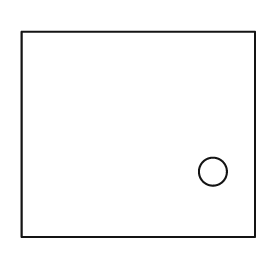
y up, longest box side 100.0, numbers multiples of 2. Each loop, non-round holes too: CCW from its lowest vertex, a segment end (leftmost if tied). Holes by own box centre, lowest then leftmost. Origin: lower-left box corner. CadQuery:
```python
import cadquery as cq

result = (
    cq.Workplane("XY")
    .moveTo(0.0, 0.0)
    .lineTo(100.0, 0.0)
    .lineTo(100.0, 88.0)
    .lineTo(0.0, 88.0)
    .close()
    .moveTo(82.0, 28.0)
    .circle(6.0)
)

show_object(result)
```